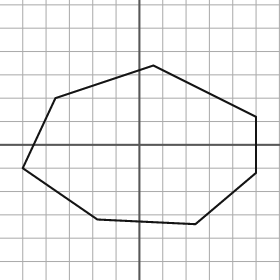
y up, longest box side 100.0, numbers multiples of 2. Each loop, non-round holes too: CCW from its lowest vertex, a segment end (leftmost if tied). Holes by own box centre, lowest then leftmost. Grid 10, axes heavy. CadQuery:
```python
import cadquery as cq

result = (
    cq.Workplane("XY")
    .moveTo(24.0, -34.0)
    .lineTo(50.0, -12.0)
    .lineTo(50.0, 12.0)
    .lineTo(6.0, 34.0)
    .lineTo(-36.0, 20.0)
    .lineTo(-50.0, -10.0)
    .lineTo(-18.0, -32.0)
    .close()
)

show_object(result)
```